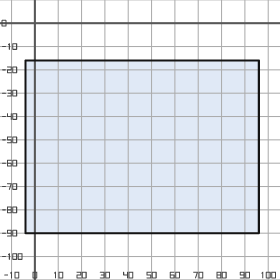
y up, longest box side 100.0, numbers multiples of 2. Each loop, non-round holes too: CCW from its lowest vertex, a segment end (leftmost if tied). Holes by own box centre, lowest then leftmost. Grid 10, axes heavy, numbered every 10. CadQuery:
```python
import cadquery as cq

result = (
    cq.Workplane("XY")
    .moveTo(-4.0, -90.0)
    .lineTo(96.0, -90.0)
    .lineTo(96.0, -16.0)
    .lineTo(-4.0, -16.0)
    .close()
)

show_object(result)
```